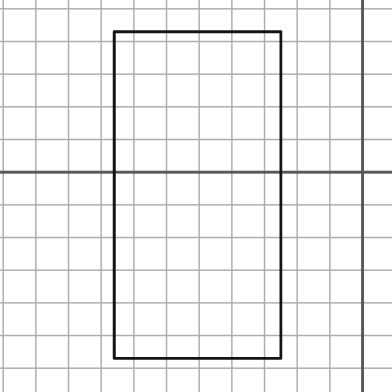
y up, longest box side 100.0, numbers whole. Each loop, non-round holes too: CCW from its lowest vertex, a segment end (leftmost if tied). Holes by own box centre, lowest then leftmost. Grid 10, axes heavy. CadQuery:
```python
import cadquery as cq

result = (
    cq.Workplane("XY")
    .moveTo(-76.0, -57.0)
    .lineTo(-25.0, -57.0)
    .lineTo(-25.0, 43.0)
    .lineTo(-76.0, 43.0)
    .close()
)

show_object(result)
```